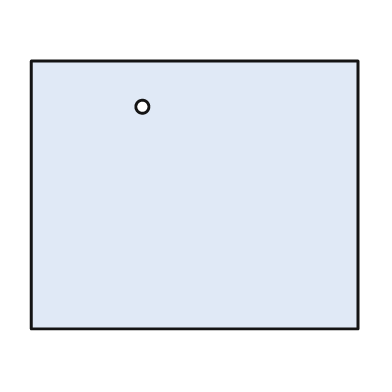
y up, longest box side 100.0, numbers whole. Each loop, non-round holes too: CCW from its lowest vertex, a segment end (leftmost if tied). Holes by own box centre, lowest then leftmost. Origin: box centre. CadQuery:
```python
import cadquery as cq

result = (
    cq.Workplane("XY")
    .moveTo(-50.0, -41.0)
    .lineTo(50.0, -41.0)
    .lineTo(50.0, 41.0)
    .lineTo(-50.0, 41.0)
    .close()
    .moveTo(-16.0, 27.0)
    .circle(2.0)
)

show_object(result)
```